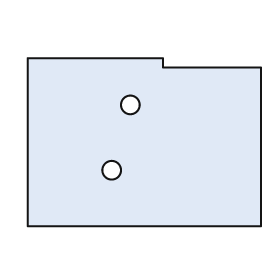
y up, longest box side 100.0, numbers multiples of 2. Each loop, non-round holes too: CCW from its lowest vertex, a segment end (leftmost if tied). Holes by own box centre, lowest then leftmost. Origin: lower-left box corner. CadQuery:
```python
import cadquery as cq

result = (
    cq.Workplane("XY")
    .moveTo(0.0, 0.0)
    .lineTo(100.0, 0.0)
    .lineTo(100.0, 68.0)
    .lineTo(58.0, 68.0)
    .lineTo(58.0, 72.0)
    .lineTo(0.0, 72.0)
    .close()
    .moveTo(36.0, 24.0)
    .circle(4.0)
    .moveTo(44.0, 52.0)
    .circle(4.0)
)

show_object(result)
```